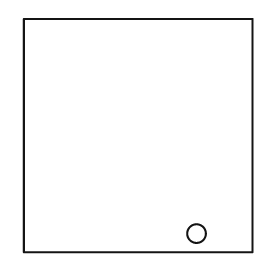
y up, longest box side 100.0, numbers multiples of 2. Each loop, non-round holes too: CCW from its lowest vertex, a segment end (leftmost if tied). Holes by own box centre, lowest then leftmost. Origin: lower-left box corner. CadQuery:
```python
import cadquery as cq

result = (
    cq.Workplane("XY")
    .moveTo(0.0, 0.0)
    .lineTo(98.0, 0.0)
    .lineTo(98.0, 100.0)
    .lineTo(0.0, 100.0)
    .close()
    .moveTo(74.0, 8.0)
    .circle(4.0)
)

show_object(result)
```